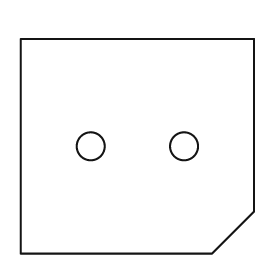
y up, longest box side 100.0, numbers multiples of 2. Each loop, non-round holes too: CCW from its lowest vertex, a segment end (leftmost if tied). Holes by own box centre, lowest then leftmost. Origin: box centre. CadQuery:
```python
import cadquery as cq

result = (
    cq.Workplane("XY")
    .moveTo(-50.0, -46.0)
    .lineTo(32.0, -46.0)
    .lineTo(50.0, -28.0)
    .lineTo(50.0, 46.0)
    .lineTo(-50.0, 46.0)
    .close()
    .moveTo(-20.0, 0.0)
    .circle(6.0)
    .moveTo(20.0, 0.0)
    .circle(6.0)
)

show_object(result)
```